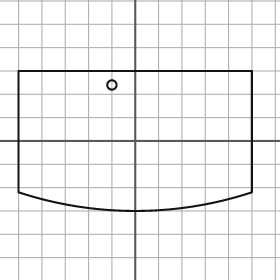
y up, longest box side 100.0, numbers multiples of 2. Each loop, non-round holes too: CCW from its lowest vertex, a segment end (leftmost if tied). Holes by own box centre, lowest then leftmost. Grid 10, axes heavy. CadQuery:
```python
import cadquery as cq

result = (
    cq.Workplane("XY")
    .moveTo(-50.0, -22.0)
    .threePointArc((0.0, -30.0), (50.0, -22.0))
    .lineTo(50.0, 30.0)
    .lineTo(-50.0, 30.0)
    .close()
    .moveTo(-10.0, 24.0)
    .circle(2.0)
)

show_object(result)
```